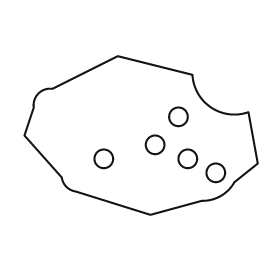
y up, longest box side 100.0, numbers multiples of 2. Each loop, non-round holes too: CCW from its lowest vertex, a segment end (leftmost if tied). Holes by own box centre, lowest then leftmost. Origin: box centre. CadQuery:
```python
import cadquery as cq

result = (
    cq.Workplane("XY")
    .moveTo(4.0, -34.0)
    .lineTo(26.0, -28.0)
    .threePointArc((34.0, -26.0), (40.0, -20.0))
    .lineTo(50.0, -12.0)
    .lineTo(46.0, 10.0)
    .threePointArc((30.0, 12.0), (22.0, 26.0))
    .lineTo(-10.0, 34.0)
    .lineTo(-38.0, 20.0)
    .threePointArc((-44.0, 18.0), (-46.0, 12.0))
    .lineTo(-50.0, 0.0)
    .lineTo(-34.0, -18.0)
    .threePointArc((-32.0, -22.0), (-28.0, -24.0))
    .close()
    .moveTo(32.0, -16.0)
    .circle(4.0)
    .moveTo(-16.0, -10.0)
    .circle(4.0)
    .moveTo(20.0, -10.0)
    .circle(4.0)
    .moveTo(6.0, -4.0)
    .circle(4.0)
    .moveTo(16.0, 8.0)
    .circle(4.0)
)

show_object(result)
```